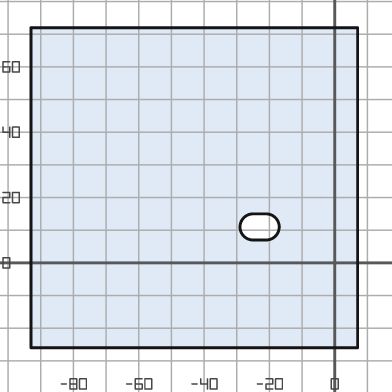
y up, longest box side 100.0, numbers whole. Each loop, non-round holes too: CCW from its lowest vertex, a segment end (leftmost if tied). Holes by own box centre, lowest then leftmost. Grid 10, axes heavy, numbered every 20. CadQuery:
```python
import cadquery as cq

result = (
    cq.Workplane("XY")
    .moveTo(-93.0, -26.0)
    .lineTo(7.0, -26.0)
    .lineTo(7.0, 72.0)
    .lineTo(-93.0, 72.0)
    .close()
    .moveTo(-25.0, 7.0)
    .lineTo(-21.0, 7.0)
    .threePointArc((-17.0, 11.0), (-21.0, 15.0))
    .lineTo(-25.0, 15.0)
    .threePointArc((-29.0, 11.0), (-25.0, 7.0))
    .close()
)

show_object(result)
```